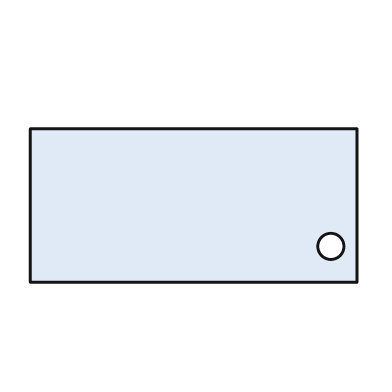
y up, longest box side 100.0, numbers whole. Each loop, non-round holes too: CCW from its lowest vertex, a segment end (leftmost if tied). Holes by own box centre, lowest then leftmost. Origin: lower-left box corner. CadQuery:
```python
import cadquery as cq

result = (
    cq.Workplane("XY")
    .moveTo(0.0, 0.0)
    .lineTo(100.0, 0.0)
    .lineTo(100.0, 47.0)
    .lineTo(0.0, 47.0)
    .close()
    .moveTo(92.0, 11.0)
    .circle(4.0)
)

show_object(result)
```